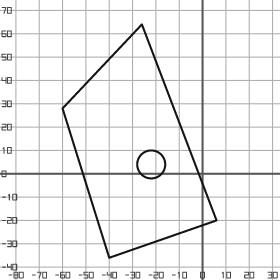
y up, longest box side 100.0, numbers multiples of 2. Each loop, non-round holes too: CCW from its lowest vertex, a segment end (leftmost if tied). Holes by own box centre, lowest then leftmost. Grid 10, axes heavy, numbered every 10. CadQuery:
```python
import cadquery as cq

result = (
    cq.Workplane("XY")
    .moveTo(-40.0, -36.0)
    .lineTo(6.0, -20.0)
    .lineTo(-26.0, 64.0)
    .lineTo(-60.0, 28.0)
    .close()
    .moveTo(-22.0, 4.0)
    .circle(6.0)
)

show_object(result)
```